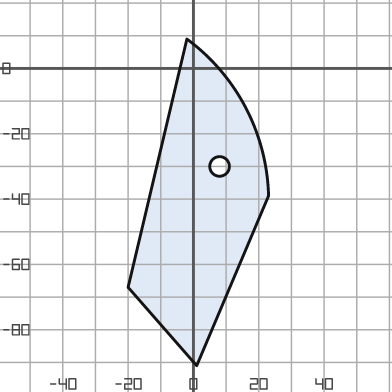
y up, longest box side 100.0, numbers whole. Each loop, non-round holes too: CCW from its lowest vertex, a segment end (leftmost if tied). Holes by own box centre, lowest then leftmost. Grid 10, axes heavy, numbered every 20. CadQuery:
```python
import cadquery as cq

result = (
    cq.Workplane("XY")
    .moveTo(1.0, -91.0)
    .lineTo(23.0, -39.0)
    .threePointArc((16.0, -12.0), (-2.0, 9.0))
    .lineTo(-20.0, -67.0)
    .close()
    .moveTo(8.0, -30.0)
    .circle(3.0)
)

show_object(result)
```